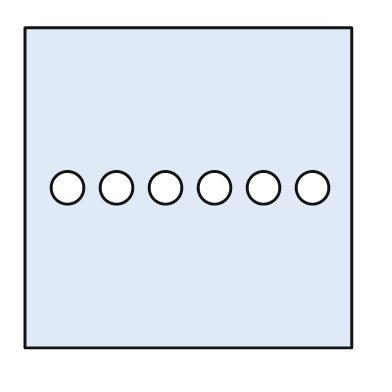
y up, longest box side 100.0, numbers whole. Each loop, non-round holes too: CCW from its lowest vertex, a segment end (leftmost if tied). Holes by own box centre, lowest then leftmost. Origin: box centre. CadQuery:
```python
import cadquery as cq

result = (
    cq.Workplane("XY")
    .moveTo(-50.0, -49.0)
    .lineTo(50.0, -49.0)
    .lineTo(50.0, 49.0)
    .lineTo(-50.0, 49.0)
    .close()
    .moveTo(-37.0, 0.0)
    .circle(5.0)
    .moveTo(-22.0, 0.0)
    .circle(5.0)
    .moveTo(-7.0, 0.0)
    .circle(5.0)
    .moveTo(8.0, 0.0)
    .circle(5.0)
    .moveTo(23.0, 0.0)
    .circle(5.0)
    .moveTo(38.0, 0.0)
    .circle(5.0)
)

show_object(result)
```